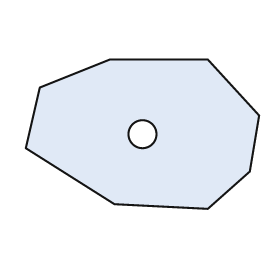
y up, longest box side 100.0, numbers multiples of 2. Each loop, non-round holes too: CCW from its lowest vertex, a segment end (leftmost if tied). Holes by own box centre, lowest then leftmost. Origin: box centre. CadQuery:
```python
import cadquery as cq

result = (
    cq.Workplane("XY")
    .moveTo(28.0, -32.0)
    .lineTo(46.0, -16.0)
    .lineTo(50.0, 8.0)
    .lineTo(28.0, 32.0)
    .lineTo(-14.0, 32.0)
    .lineTo(-44.0, 20.0)
    .lineTo(-50.0, -6.0)
    .lineTo(-12.0, -30.0)
    .close()
    .moveTo(0.0, 0.0)
    .circle(6.0)
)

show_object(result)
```